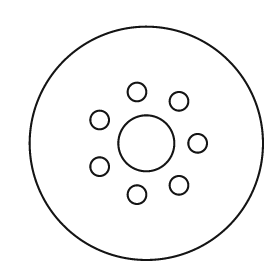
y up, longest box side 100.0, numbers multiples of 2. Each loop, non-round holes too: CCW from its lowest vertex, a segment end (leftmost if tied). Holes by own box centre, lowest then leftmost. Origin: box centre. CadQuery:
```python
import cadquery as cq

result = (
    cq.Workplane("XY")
    .moveTo(0.0, 0.0)
    .circle(50.0)
    .moveTo(-4.0, -22.0)
    .circle(4.0)
    .moveTo(14.0, -18.0)
    .circle(4.0)
    .moveTo(-20.0, -10.0)
    .circle(4.0)
    .moveTo(0.0, 0.0)
    .circle(12.0)
    .moveTo(22.0, 0.0)
    .circle(4.0)
    .moveTo(-20.0, 10.0)
    .circle(4.0)
    .moveTo(14.0, 18.0)
    .circle(4.0)
    .moveTo(-4.0, 22.0)
    .circle(4.0)
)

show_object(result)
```